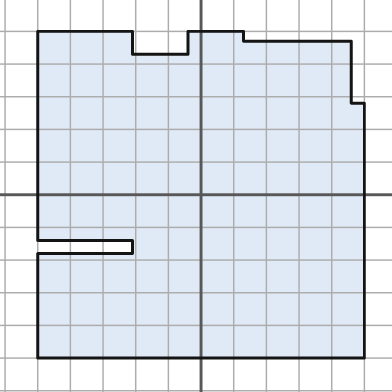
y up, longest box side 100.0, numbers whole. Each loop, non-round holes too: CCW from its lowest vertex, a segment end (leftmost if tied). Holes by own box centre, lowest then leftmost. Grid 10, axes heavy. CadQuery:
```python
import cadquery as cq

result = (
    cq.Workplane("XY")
    .moveTo(-50.0, -50.0)
    .lineTo(50.0, -50.0)
    .lineTo(50.0, 28.0)
    .lineTo(46.0, 28.0)
    .lineTo(46.0, 47.0)
    .lineTo(13.0, 47.0)
    .lineTo(13.0, 50.0)
    .lineTo(-4.0, 50.0)
    .lineTo(-4.0, 43.0)
    .lineTo(-21.0, 43.0)
    .lineTo(-21.0, 50.0)
    .lineTo(-50.0, 50.0)
    .lineTo(-50.0, -14.0)
    .lineTo(-21.0, -14.0)
    .lineTo(-21.0, -18.0)
    .lineTo(-50.0, -18.0)
    .close()
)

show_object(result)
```